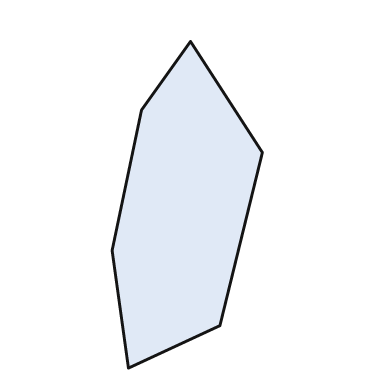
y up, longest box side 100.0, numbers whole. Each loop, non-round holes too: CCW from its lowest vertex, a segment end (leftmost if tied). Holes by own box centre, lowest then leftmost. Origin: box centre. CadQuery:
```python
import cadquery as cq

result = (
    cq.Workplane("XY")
    .moveTo(-18.0, -50.0)
    .lineTo(10.0, -37.0)
    .lineTo(23.0, 16.0)
    .lineTo(1.0, 50.0)
    .lineTo(-14.0, 29.0)
    .lineTo(-23.0, -14.0)
    .close()
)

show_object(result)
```